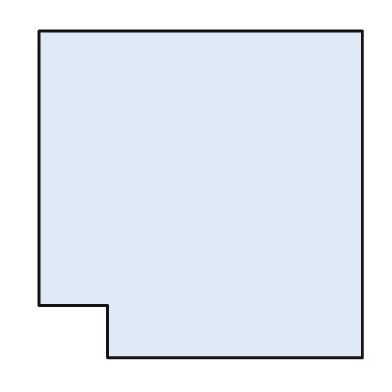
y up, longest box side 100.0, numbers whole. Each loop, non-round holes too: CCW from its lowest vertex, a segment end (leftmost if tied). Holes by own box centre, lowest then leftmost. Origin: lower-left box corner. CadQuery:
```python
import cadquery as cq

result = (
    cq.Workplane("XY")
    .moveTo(21.0, 0.0)
    .lineTo(99.0, 0.0)
    .lineTo(99.0, 100.0)
    .lineTo(0.0, 100.0)
    .lineTo(0.0, 16.0)
    .lineTo(21.0, 16.0)
    .close()
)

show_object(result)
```